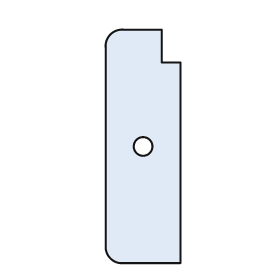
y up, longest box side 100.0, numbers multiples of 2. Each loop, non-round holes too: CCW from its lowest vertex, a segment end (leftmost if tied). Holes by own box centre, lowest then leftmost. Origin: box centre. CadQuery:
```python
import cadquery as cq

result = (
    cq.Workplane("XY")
    .moveTo(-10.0, -50.0)
    .lineTo(16.0, -50.0)
    .lineTo(16.0, 36.0)
    .lineTo(8.0, 36.0)
    .lineTo(8.0, 50.0)
    .lineTo(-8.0, 50.0)
    .threePointArc((-14.0, 48.0), (-16.0, 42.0))
    .lineTo(-16.0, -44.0)
    .threePointArc((-14.0, -48.0), (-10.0, -50.0))
    .close()
    .moveTo(0.0, 0.0)
    .circle(4.0)
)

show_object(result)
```